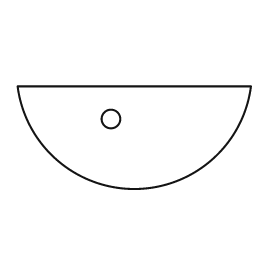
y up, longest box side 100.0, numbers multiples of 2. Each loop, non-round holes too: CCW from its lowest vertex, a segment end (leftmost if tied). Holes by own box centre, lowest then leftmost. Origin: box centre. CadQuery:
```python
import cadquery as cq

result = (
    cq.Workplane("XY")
    .moveTo(-50.0, 22.0)
    .threePointArc((0.0, -22.0), (50.0, 22.0))
    .close()
    .moveTo(-10.0, 8.0)
    .circle(4.0)
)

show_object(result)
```